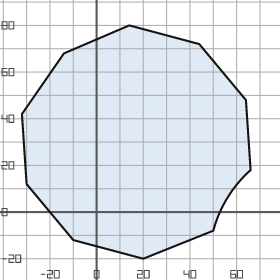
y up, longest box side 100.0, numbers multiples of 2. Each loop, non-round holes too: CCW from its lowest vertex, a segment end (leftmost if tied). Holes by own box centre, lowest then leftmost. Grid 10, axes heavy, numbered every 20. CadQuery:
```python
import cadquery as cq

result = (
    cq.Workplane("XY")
    .moveTo(20.0, -20.0)
    .lineTo(50.0, -8.0)
    .threePointArc((56.0, 6.0), (66.0, 18.0))
    .lineTo(64.0, 48.0)
    .lineTo(44.0, 72.0)
    .lineTo(14.0, 80.0)
    .lineTo(-14.0, 68.0)
    .lineTo(-32.0, 42.0)
    .lineTo(-30.0, 12.0)
    .lineTo(-10.0, -12.0)
    .close()
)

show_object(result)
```